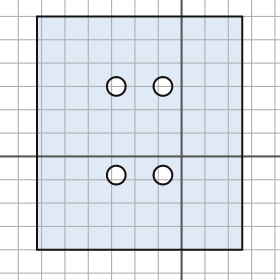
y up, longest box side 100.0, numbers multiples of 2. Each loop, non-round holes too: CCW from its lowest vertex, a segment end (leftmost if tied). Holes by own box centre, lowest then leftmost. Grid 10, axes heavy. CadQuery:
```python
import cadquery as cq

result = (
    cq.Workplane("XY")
    .moveTo(-62.0, -40.0)
    .lineTo(26.0, -40.0)
    .lineTo(26.0, 60.0)
    .lineTo(-62.0, 60.0)
    .close()
    .moveTo(-28.0, -8.0)
    .circle(4.0)
    .moveTo(-8.0, -8.0)
    .circle(4.0)
    .moveTo(-28.0, 30.0)
    .circle(4.0)
    .moveTo(-8.0, 30.0)
    .circle(4.0)
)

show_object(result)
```